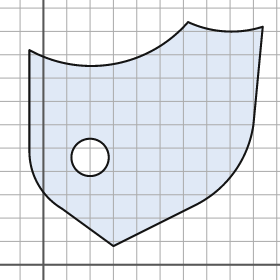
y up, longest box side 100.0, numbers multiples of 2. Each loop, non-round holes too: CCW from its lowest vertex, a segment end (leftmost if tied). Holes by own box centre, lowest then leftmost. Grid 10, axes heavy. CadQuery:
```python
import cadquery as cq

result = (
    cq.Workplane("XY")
    .moveTo(30.0, 8.0)
    .lineTo(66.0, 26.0)
    .threePointArc((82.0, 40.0), (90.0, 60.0))
    .lineTo(94.0, 102.0)
    .threePointArc((78.0, 100.0), (62.0, 104.0))
    .threePointArc((30.0, 86.0), (-6.0, 92.0))
    .lineTo(-6.0, 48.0)
    .threePointArc((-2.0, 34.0), (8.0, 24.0))
    .close()
    .moveTo(20.0, 46.0)
    .circle(8.0)
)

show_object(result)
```